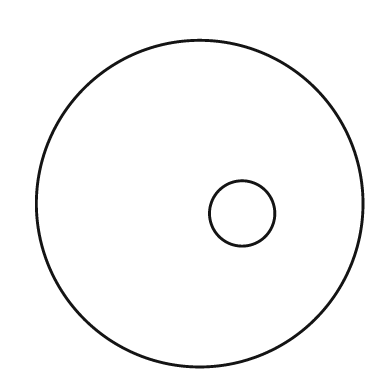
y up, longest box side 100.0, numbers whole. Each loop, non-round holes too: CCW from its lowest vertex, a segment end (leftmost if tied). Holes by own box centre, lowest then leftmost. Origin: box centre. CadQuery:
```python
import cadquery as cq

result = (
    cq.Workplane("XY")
    .moveTo(0.0, 0.0)
    .circle(50.0)
    .moveTo(13.0, -3.0)
    .circle(10.0)
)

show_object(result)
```